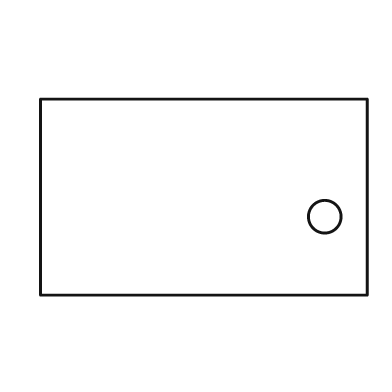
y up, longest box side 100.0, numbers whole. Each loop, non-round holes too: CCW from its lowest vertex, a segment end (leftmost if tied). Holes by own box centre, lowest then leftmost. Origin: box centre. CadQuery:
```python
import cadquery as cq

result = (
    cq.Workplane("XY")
    .moveTo(-50.0, -30.0)
    .lineTo(50.0, -30.0)
    .lineTo(50.0, 30.0)
    .lineTo(-50.0, 30.0)
    .close()
    .moveTo(37.0, -6.0)
    .circle(5.0)
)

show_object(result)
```